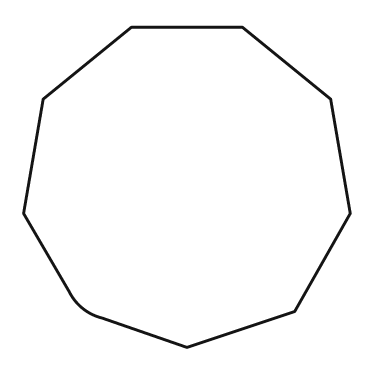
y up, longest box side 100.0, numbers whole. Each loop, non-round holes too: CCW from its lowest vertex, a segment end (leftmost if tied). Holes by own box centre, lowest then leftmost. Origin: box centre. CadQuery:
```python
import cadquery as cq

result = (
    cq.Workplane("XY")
    .moveTo(0.0, -49.0)
    .lineTo(33.0, -38.0)
    .lineTo(50.0, -8.0)
    .lineTo(44.0, 27.0)
    .lineTo(17.0, 49.0)
    .lineTo(-17.0, 49.0)
    .lineTo(-44.0, 27.0)
    .lineTo(-50.0, -8.0)
    .lineTo(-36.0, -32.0)
    .threePointArc((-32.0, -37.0), (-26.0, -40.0))
    .close()
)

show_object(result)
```